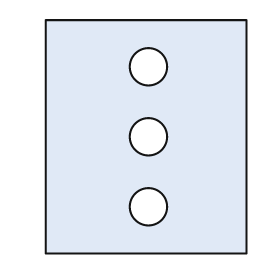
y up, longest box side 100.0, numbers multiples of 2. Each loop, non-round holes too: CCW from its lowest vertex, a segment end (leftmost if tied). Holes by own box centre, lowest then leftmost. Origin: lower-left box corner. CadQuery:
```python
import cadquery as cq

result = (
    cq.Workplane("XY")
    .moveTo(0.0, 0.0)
    .lineTo(86.0, 0.0)
    .lineTo(86.0, 100.0)
    .lineTo(0.0, 100.0)
    .close()
    .moveTo(44.0, 20.0)
    .circle(8.0)
    .moveTo(44.0, 50.0)
    .circle(8.0)
    .moveTo(44.0, 80.0)
    .circle(8.0)
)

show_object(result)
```